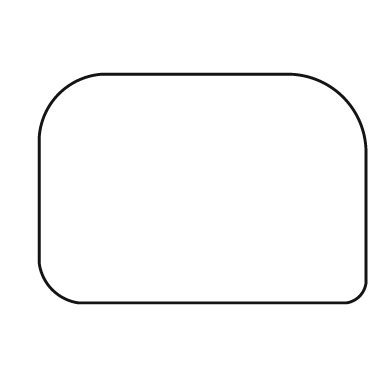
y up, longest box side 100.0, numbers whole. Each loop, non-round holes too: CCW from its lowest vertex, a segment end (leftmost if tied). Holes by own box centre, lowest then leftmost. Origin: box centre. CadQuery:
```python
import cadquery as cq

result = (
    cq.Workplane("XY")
    .moveTo(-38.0, -35.0)
    .lineTo(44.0, -35.0)
    .threePointArc((48.0, -33.0), (50.0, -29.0))
    .lineTo(50.0, 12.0)
    .threePointArc((43.0, 28.0), (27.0, 35.0))
    .lineTo(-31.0, 35.0)
    .threePointArc((-44.0, 29.0), (-50.0, 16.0))
    .lineTo(-50.0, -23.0)
    .threePointArc((-46.0, -31.0), (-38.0, -35.0))
    .close()
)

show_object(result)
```